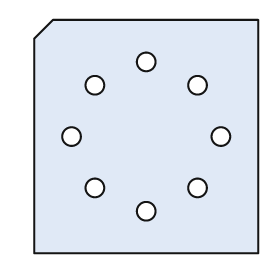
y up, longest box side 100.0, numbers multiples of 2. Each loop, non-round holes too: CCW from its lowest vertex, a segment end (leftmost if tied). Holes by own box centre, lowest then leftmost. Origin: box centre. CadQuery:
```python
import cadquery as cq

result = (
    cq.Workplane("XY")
    .moveTo(-48.0, -50.0)
    .lineTo(48.0, -50.0)
    .lineTo(48.0, 50.0)
    .lineTo(-40.0, 50.0)
    .lineTo(-48.0, 42.0)
    .close()
    .moveTo(0.0, -32.0)
    .circle(4.0)
    .moveTo(-22.0, -22.0)
    .circle(4.0)
    .moveTo(22.0, -22.0)
    .circle(4.0)
    .moveTo(-32.0, 0.0)
    .circle(4.0)
    .moveTo(32.0, 0.0)
    .circle(4.0)
    .moveTo(-22.0, 22.0)
    .circle(4.0)
    .moveTo(22.0, 22.0)
    .circle(4.0)
    .moveTo(0.0, 32.0)
    .circle(4.0)
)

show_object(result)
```